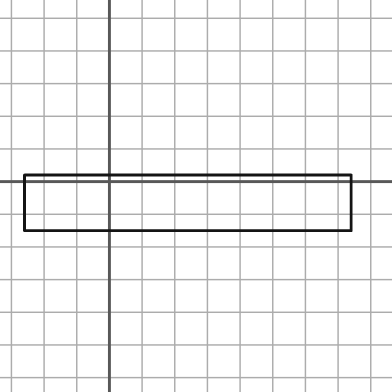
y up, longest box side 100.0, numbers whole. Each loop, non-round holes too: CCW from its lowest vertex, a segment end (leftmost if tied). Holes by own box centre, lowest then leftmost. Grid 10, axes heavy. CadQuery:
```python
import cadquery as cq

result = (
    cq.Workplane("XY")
    .moveTo(-26.0, -15.0)
    .lineTo(74.0, -15.0)
    .lineTo(74.0, 2.0)
    .lineTo(-26.0, 2.0)
    .close()
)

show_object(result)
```